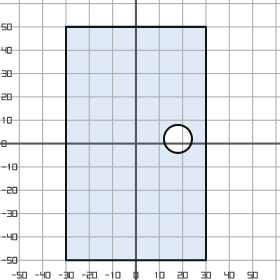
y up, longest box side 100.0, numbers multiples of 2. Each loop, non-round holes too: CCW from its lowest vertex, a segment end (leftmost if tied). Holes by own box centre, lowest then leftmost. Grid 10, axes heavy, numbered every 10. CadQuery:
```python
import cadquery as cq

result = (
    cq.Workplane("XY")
    .moveTo(-30.0, -50.0)
    .lineTo(30.0, -50.0)
    .lineTo(30.0, 50.0)
    .lineTo(-30.0, 50.0)
    .close()
    .moveTo(18.0, 2.0)
    .circle(6.0)
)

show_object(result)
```